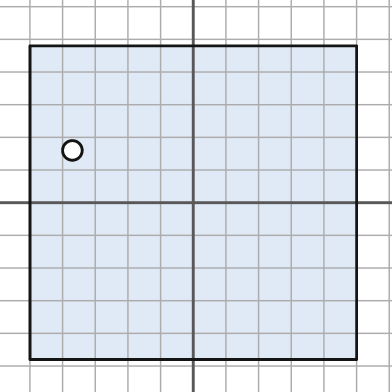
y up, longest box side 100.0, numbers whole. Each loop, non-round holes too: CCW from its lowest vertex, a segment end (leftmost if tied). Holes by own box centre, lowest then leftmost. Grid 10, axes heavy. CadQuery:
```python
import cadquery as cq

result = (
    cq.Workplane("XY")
    .moveTo(-50.0, -48.0)
    .lineTo(50.0, -48.0)
    .lineTo(50.0, 48.0)
    .lineTo(-50.0, 48.0)
    .close()
    .moveTo(-37.0, 16.0)
    .circle(3.0)
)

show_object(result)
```